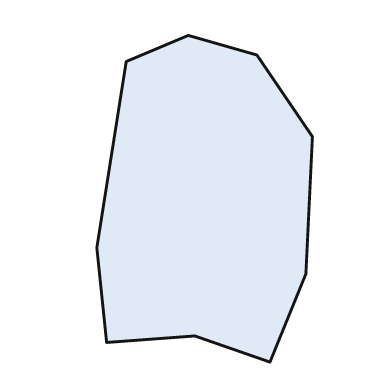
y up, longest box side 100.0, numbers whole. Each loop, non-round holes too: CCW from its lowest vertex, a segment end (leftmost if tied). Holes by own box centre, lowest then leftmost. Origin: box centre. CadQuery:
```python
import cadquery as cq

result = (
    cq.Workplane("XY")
    .moveTo(20.0, -50.0)
    .lineTo(31.0, -23.0)
    .lineTo(33.0, 19.0)
    .lineTo(16.0, 44.0)
    .lineTo(-5.0, 50.0)
    .lineTo(-24.0, 42.0)
    .lineTo(-33.0, -15.0)
    .lineTo(-30.0, -44.0)
    .lineTo(-3.0, -42.0)
    .close()
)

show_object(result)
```